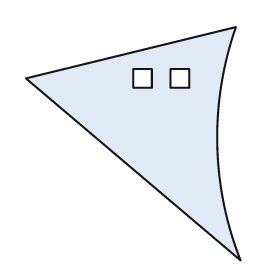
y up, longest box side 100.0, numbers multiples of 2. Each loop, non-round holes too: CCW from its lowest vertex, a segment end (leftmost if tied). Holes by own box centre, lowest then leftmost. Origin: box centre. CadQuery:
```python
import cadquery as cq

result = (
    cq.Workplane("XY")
    .moveTo(46.0, -50.0)
    .threePointArc((36.0, 0.0), (44.0, 50.0))
    .lineTo(-46.0, 28.0)
    .close()
    .moveTo(0.0, 24.0)
    .lineTo(8.0, 24.0)
    .lineTo(8.0, 32.0)
    .lineTo(0.0, 32.0)
    .close()
    .moveTo(16.0, 24.0)
    .lineTo(24.0, 24.0)
    .lineTo(24.0, 32.0)
    .lineTo(16.0, 32.0)
    .close()
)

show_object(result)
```